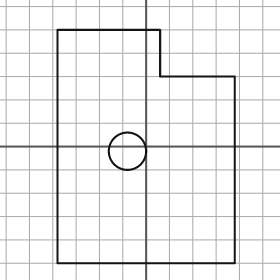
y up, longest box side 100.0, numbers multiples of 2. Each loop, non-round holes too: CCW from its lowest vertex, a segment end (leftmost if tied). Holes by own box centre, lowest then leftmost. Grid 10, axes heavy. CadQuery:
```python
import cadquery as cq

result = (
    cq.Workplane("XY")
    .moveTo(-38.0, -50.0)
    .lineTo(38.0, -50.0)
    .lineTo(38.0, 30.0)
    .lineTo(6.0, 30.0)
    .lineTo(6.0, 50.0)
    .lineTo(-38.0, 50.0)
    .close()
    .moveTo(-8.0, -2.0)
    .circle(8.0)
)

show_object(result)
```